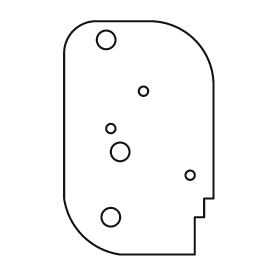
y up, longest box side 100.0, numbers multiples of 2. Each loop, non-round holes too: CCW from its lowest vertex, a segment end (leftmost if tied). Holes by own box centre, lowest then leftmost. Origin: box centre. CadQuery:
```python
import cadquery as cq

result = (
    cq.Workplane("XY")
    .moveTo(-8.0, -50.0)
    .lineTo(24.0, -50.0)
    .lineTo(24.0, -34.0)
    .lineTo(28.0, -34.0)
    .lineTo(28.0, -26.0)
    .lineTo(32.0, -26.0)
    .lineTo(32.0, 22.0)
    .threePointArc((24.0, 42.0), (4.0, 50.0))
    .lineTo(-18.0, 50.0)
    .threePointArc((-28.0, 46.0), (-32.0, 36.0))
    .lineTo(-32.0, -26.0)
    .threePointArc((-24.0, -42.0), (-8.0, -50.0))
    .close()
    .moveTo(-12.0, -34.0)
    .circle(4.0)
    .moveTo(22.0, -16.0)
    .circle(2.0)
    .moveTo(-8.0, -6.0)
    .circle(4.0)
    .moveTo(-12.0, 4.0)
    .circle(2.0)
    .moveTo(2.0, 20.0)
    .circle(2.0)
    .moveTo(-14.0, 42.0)
    .circle(4.0)
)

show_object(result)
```